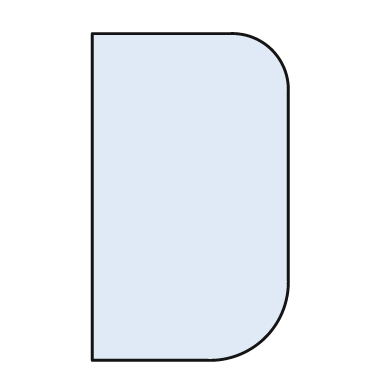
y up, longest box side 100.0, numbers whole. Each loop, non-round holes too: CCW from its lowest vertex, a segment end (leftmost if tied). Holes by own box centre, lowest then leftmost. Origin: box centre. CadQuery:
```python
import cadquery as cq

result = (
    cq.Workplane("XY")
    .moveTo(-30.0, -50.0)
    .lineTo(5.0, -50.0)
    .threePointArc((23.0, -43.0), (30.0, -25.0))
    .lineTo(30.0, 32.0)
    .threePointArc((25.0, 45.0), (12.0, 50.0))
    .lineTo(-30.0, 50.0)
    .close()
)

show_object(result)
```